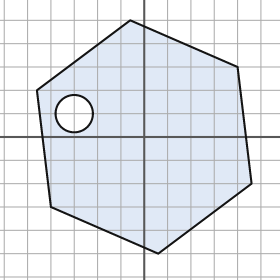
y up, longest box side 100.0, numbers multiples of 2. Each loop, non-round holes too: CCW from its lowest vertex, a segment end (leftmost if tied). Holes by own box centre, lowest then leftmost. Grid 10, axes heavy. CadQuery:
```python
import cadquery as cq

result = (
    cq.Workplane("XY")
    .moveTo(6.0, -50.0)
    .lineTo(46.0, -20.0)
    .lineTo(40.0, 30.0)
    .lineTo(-6.0, 50.0)
    .lineTo(-46.0, 20.0)
    .lineTo(-40.0, -30.0)
    .close()
    .moveTo(-30.0, 10.0)
    .circle(8.0)
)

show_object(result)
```